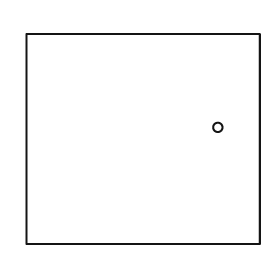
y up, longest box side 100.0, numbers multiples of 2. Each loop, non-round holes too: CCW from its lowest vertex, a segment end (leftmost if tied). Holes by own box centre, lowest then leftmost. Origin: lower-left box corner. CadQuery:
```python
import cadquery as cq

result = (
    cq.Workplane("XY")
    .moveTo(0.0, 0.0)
    .lineTo(100.0, 0.0)
    .lineTo(100.0, 90.0)
    .lineTo(0.0, 90.0)
    .close()
    .moveTo(82.0, 50.0)
    .circle(2.0)
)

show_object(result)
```